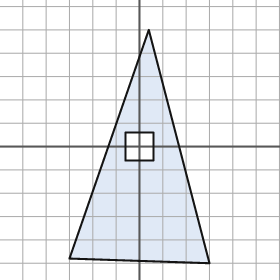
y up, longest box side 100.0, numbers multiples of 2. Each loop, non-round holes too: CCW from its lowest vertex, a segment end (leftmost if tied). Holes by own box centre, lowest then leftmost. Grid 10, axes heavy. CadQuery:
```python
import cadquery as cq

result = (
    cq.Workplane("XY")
    .moveTo(30.0, -50.0)
    .lineTo(4.0, 50.0)
    .lineTo(-30.0, -48.0)
    .close()
    .moveTo(-6.0, -6.0)
    .lineTo(6.0, -6.0)
    .lineTo(6.0, 6.0)
    .lineTo(-6.0, 6.0)
    .close()
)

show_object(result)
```